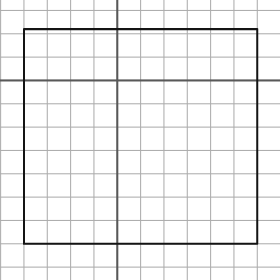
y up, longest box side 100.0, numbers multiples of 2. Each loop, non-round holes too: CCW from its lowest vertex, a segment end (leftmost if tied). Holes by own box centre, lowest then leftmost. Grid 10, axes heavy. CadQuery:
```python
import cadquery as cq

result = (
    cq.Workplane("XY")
    .moveTo(-40.0, -70.0)
    .lineTo(60.0, -70.0)
    .lineTo(60.0, 22.0)
    .lineTo(-40.0, 22.0)
    .close()
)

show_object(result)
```